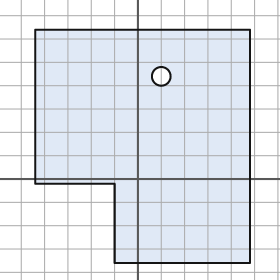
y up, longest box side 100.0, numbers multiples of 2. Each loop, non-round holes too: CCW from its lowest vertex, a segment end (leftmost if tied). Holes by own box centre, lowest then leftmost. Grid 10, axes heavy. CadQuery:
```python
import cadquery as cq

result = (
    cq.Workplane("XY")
    .moveTo(-10.0, -36.0)
    .lineTo(48.0, -36.0)
    .lineTo(48.0, 64.0)
    .lineTo(-44.0, 64.0)
    .lineTo(-44.0, -2.0)
    .lineTo(-10.0, -2.0)
    .close()
    .moveTo(10.0, 44.0)
    .circle(4.0)
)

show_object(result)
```